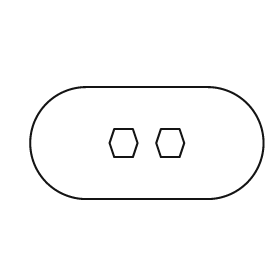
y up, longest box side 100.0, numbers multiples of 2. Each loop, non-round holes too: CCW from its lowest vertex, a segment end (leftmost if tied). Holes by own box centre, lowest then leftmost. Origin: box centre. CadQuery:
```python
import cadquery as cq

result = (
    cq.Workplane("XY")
    .moveTo(-26.0, -24.0)
    .lineTo(26.0, -24.0)
    .threePointArc((50.0, 0.0), (26.0, 24.0))
    .lineTo(-26.0, 24.0)
    .threePointArc((-50.0, 0.0), (-26.0, -24.0))
    .close()
    .moveTo(-14.0, -6.0)
    .lineTo(-6.0, -6.0)
    .lineTo(-4.0, 0.0)
    .lineTo(-6.0, 6.0)
    .lineTo(-14.0, 6.0)
    .lineTo(-16.0, 0.0)
    .close()
    .moveTo(6.0, -6.0)
    .lineTo(14.0, -6.0)
    .lineTo(16.0, 0.0)
    .lineTo(14.0, 6.0)
    .lineTo(6.0, 6.0)
    .lineTo(4.0, 0.0)
    .close()
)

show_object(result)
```